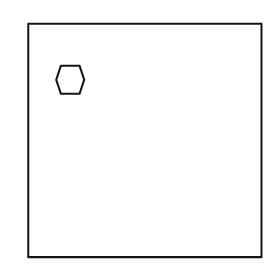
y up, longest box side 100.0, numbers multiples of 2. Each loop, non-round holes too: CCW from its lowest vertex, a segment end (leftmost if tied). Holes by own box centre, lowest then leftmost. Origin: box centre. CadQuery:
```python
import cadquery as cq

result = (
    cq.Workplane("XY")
    .moveTo(-50.0, -50.0)
    .lineTo(50.0, -50.0)
    .lineTo(50.0, 50.0)
    .lineTo(-50.0, 50.0)
    .close()
    .moveTo(-36.0, 20.0)
    .lineTo(-28.0, 20.0)
    .lineTo(-26.0, 26.0)
    .lineTo(-28.0, 32.0)
    .lineTo(-36.0, 32.0)
    .lineTo(-38.0, 26.0)
    .close()
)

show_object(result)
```